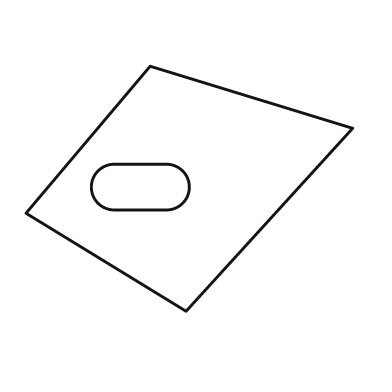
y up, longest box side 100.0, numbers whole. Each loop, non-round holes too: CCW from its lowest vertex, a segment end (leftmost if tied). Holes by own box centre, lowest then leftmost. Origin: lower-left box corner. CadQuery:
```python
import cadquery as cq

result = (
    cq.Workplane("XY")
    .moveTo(49.0, 0.0)
    .lineTo(100.0, 56.0)
    .lineTo(38.0, 75.0)
    .lineTo(0.0, 30.0)
    .close()
    .moveTo(27.0, 31.0)
    .lineTo(43.0, 31.0)
    .threePointArc((50.0, 38.0), (43.0, 45.0))
    .lineTo(27.0, 45.0)
    .threePointArc((20.0, 38.0), (27.0, 31.0))
    .close()
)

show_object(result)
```